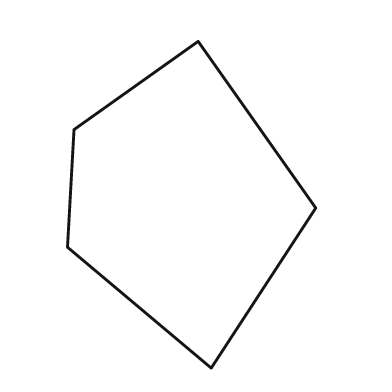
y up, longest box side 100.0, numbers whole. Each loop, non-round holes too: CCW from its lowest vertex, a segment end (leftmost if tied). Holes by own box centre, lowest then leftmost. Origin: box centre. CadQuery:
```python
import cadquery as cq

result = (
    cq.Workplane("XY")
    .moveTo(6.0, -50.0)
    .lineTo(38.0, -1.0)
    .lineTo(2.0, 50.0)
    .lineTo(-36.0, 23.0)
    .lineTo(-38.0, -13.0)
    .close()
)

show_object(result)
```